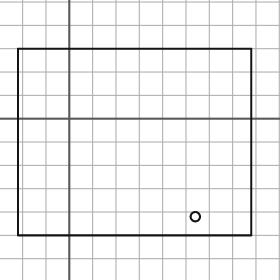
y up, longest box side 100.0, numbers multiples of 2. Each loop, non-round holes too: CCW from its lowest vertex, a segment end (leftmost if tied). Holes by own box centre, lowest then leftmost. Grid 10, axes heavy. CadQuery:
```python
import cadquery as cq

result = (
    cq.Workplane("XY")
    .moveTo(-22.0, -50.0)
    .lineTo(78.0, -50.0)
    .lineTo(78.0, 30.0)
    .lineTo(-22.0, 30.0)
    .close()
    .moveTo(54.0, -42.0)
    .circle(2.0)
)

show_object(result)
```